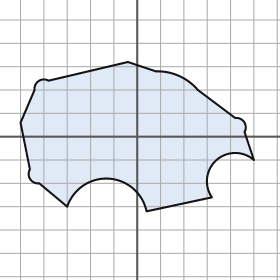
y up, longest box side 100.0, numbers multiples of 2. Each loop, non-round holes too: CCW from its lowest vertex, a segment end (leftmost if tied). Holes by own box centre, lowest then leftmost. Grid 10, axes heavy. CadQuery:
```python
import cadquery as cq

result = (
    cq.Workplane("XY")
    .moveTo(4.0, -32.0)
    .lineTo(32.0, -26.0)
    .threePointArc((34.0, -10.0), (50.0, -10.0))
    .lineTo(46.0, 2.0)
    .threePointArc((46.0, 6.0), (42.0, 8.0))
    .lineTo(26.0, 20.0)
    .threePointArc((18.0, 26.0), (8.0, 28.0))
    .lineTo(-4.0, 32.0)
    .lineTo(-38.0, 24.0)
    .threePointArc((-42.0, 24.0), (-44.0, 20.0))
    .lineTo(-50.0, 6.0)
    .lineTo(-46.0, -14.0)
    .threePointArc((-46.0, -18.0), (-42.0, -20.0))
    .lineTo(-30.0, -30.0)
    .threePointArc((-12.0, -18.0), (4.0, -32.0))
    .close()
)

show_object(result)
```